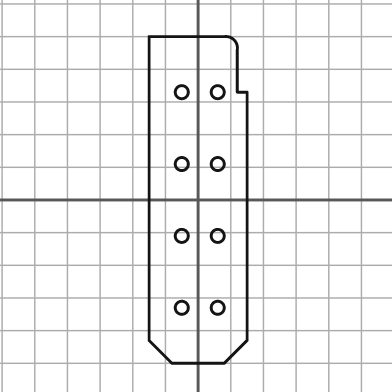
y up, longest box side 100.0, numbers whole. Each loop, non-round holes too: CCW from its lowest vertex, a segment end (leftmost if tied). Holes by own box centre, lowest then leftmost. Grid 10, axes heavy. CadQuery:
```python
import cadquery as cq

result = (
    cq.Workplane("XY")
    .moveTo(-8.0, -50.0)
    .lineTo(8.0, -50.0)
    .lineTo(15.0, -43.0)
    .lineTo(15.0, 33.0)
    .lineTo(12.0, 33.0)
    .lineTo(12.0, 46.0)
    .threePointArc((11.0, 49.0), (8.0, 50.0))
    .lineTo(-15.0, 50.0)
    .lineTo(-15.0, -43.0)
    .close()
    .moveTo(-5.0, -33.0)
    .circle(2.0)
    .moveTo(6.0, -33.0)
    .circle(2.0)
    .moveTo(-5.0, -11.0)
    .circle(2.0)
    .moveTo(6.0, -11.0)
    .circle(2.0)
    .moveTo(-5.0, 11.0)
    .circle(2.0)
    .moveTo(6.0, 11.0)
    .circle(2.0)
    .moveTo(-5.0, 33.0)
    .circle(2.0)
    .moveTo(6.0, 33.0)
    .circle(2.0)
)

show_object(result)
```